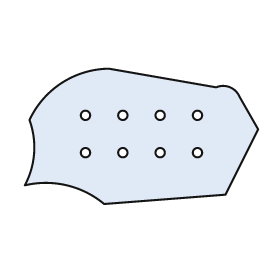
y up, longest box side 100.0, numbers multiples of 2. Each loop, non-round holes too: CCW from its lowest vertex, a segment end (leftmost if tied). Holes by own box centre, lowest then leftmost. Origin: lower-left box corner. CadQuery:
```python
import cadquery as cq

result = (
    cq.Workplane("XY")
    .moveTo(34.0, 0.0)
    .lineTo(86.0, 4.0)
    .lineTo(100.0, 32.0)
    .lineTo(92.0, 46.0)
    .threePointArc((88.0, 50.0), (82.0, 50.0))
    .lineTo(36.0, 58.0)
    .threePointArc((16.0, 52.0), (2.0, 36.0))
    .threePointArc((4.0, 22.0), (0.0, 8.0))
    .threePointArc((18.0, 8.0), (34.0, 0.0))
    .close()
    .moveTo(26.0, 22.0)
    .circle(2.0)
    .moveTo(42.0, 22.0)
    .circle(2.0)
    .moveTo(58.0, 22.0)
    .circle(2.0)
    .moveTo(74.0, 22.0)
    .circle(2.0)
    .moveTo(26.0, 38.0)
    .circle(2.0)
    .moveTo(42.0, 38.0)
    .circle(2.0)
    .moveTo(58.0, 38.0)
    .circle(2.0)
    .moveTo(74.0, 38.0)
    .circle(2.0)
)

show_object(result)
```